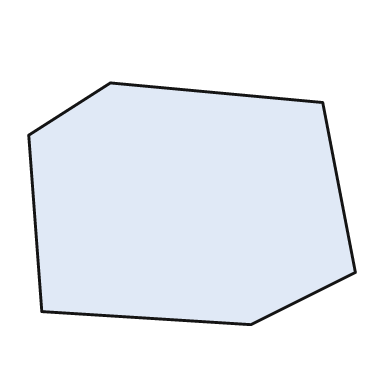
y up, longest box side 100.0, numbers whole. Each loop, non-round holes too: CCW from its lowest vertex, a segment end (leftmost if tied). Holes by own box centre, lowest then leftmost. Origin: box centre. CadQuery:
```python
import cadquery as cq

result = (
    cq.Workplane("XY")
    .moveTo(18.0, -37.0)
    .lineTo(50.0, -21.0)
    .lineTo(40.0, 31.0)
    .lineTo(-25.0, 37.0)
    .lineTo(-50.0, 21.0)
    .lineTo(-46.0, -33.0)
    .close()
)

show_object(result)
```